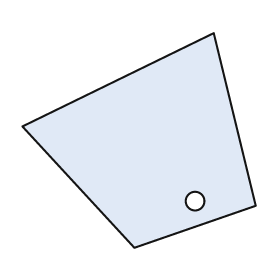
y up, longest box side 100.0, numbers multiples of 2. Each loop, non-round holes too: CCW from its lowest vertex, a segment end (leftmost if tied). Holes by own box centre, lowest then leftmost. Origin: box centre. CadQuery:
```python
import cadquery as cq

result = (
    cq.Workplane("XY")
    .moveTo(-2.0, -46.0)
    .lineTo(50.0, -28.0)
    .lineTo(32.0, 46.0)
    .lineTo(-50.0, 6.0)
    .close()
    .moveTo(24.0, -26.0)
    .circle(4.0)
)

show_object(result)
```